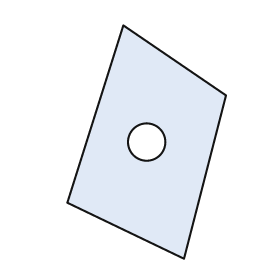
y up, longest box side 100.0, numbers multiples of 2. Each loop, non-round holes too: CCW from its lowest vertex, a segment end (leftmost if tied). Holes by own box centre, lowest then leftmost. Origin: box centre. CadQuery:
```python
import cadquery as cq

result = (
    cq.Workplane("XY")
    .moveTo(16.0, -50.0)
    .lineTo(34.0, 20.0)
    .lineTo(-10.0, 50.0)
    .lineTo(-34.0, -26.0)
    .close()
    .moveTo(0.0, 0.0)
    .circle(8.0)
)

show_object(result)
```